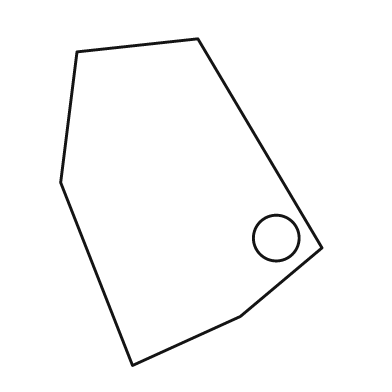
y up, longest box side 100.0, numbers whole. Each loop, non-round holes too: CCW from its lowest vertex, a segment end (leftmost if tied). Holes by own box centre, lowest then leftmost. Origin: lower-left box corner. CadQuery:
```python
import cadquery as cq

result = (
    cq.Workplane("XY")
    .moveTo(22.0, 0.0)
    .lineTo(55.0, 15.0)
    .lineTo(80.0, 36.0)
    .lineTo(42.0, 100.0)
    .lineTo(5.0, 96.0)
    .lineTo(0.0, 56.0)
    .close()
    .moveTo(66.0, 39.0)
    .circle(7.0)
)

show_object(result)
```